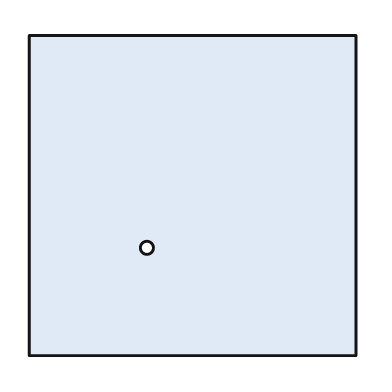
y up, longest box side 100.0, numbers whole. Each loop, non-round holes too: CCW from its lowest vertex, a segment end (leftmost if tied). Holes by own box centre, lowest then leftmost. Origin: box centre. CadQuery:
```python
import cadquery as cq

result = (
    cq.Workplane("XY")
    .moveTo(-50.0, -49.0)
    .lineTo(50.0, -49.0)
    .lineTo(50.0, 49.0)
    .lineTo(-50.0, 49.0)
    .close()
    .moveTo(-14.0, -16.0)
    .circle(2.0)
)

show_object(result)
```